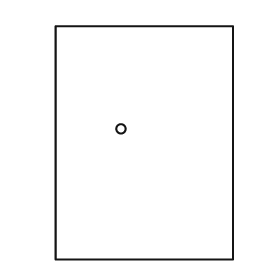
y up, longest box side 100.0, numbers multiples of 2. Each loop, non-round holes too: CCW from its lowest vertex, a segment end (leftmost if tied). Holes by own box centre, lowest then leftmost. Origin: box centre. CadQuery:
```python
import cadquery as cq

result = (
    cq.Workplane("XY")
    .moveTo(-38.0, -50.0)
    .lineTo(38.0, -50.0)
    .lineTo(38.0, 50.0)
    .lineTo(-38.0, 50.0)
    .close()
    .moveTo(-10.0, 6.0)
    .circle(2.0)
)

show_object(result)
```